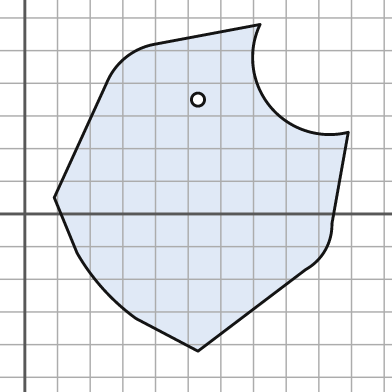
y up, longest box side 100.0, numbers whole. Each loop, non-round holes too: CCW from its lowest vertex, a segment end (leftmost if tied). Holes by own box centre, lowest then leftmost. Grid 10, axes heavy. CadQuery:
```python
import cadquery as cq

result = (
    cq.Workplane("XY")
    .moveTo(53.0, -42.0)
    .lineTo(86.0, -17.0)
    .threePointArc((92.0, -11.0), (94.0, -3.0))
    .lineTo(99.0, 25.0)
    .threePointArc((75.0, 33.0), (72.0, 58.0))
    .lineTo(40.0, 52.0)
    .threePointArc((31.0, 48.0), (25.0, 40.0))
    .lineTo(9.0, 5.0)
    .lineTo(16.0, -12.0)
    .threePointArc((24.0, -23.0), (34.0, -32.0))
    .close()
    .moveTo(53.0, 35.0)
    .circle(2.0)
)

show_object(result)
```